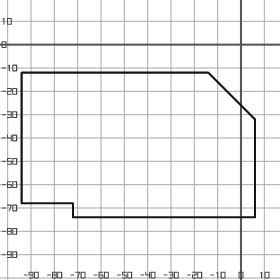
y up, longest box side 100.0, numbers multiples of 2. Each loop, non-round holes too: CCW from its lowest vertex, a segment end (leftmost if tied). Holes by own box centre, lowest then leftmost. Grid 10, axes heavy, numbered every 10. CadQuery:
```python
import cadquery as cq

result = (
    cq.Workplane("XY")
    .moveTo(-72.0, -74.0)
    .lineTo(6.0, -74.0)
    .lineTo(6.0, -32.0)
    .lineTo(-14.0, -12.0)
    .lineTo(-94.0, -12.0)
    .lineTo(-94.0, -68.0)
    .lineTo(-72.0, -68.0)
    .close()
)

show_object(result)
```